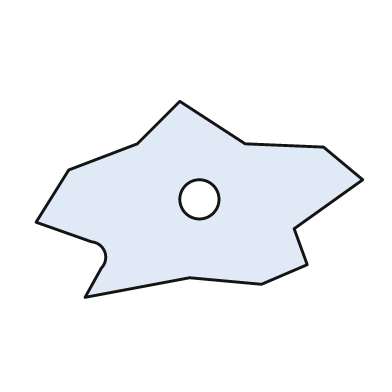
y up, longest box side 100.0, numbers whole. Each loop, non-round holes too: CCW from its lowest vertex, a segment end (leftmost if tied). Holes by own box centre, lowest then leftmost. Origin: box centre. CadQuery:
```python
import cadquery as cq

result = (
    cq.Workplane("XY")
    .moveTo(-35.0, -30.0)
    .lineTo(-3.0, -24.0)
    .lineTo(19.0, -26.0)
    .lineTo(33.0, -20.0)
    .lineTo(29.0, -9.0)
    .lineTo(50.0, 6.0)
    .lineTo(38.0, 16.0)
    .lineTo(14.0, 17.0)
    .lineTo(-6.0, 30.0)
    .lineTo(-19.0, 17.0)
    .lineTo(-40.0, 9.0)
    .lineTo(-50.0, -7.0)
    .lineTo(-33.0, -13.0)
    .threePointArc((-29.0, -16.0), (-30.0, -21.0))
    .close()
    .moveTo(0.0, 0.0)
    .circle(6.0)
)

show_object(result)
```